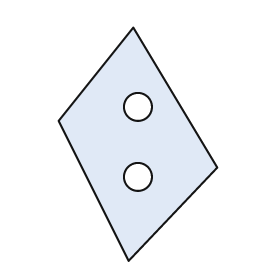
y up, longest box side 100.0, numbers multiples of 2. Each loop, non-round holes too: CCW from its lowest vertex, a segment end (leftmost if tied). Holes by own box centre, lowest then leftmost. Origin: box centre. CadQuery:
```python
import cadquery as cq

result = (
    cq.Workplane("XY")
    .moveTo(-4.0, -50.0)
    .lineTo(34.0, -10.0)
    .lineTo(-2.0, 50.0)
    .lineTo(-34.0, 10.0)
    .close()
    .moveTo(0.0, -14.0)
    .circle(6.0)
    .moveTo(0.0, 16.0)
    .circle(6.0)
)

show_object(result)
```